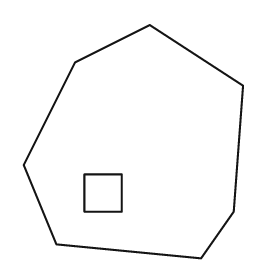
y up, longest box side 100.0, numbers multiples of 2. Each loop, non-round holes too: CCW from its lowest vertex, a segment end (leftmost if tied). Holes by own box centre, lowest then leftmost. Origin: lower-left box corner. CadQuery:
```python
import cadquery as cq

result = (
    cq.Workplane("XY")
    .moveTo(76.0, 0.0)
    .lineTo(90.0, 20.0)
    .lineTo(94.0, 74.0)
    .lineTo(54.0, 100.0)
    .lineTo(22.0, 84.0)
    .lineTo(0.0, 40.0)
    .lineTo(14.0, 6.0)
    .close()
    .moveTo(26.0, 20.0)
    .lineTo(42.0, 20.0)
    .lineTo(42.0, 36.0)
    .lineTo(26.0, 36.0)
    .close()
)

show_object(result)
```